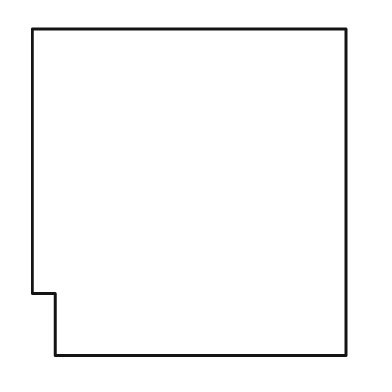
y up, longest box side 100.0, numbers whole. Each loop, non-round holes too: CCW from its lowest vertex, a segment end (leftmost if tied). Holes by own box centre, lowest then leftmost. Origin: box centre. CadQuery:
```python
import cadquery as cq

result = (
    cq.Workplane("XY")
    .moveTo(-41.0, -50.0)
    .lineTo(48.0, -50.0)
    .lineTo(48.0, 50.0)
    .lineTo(-48.0, 50.0)
    .lineTo(-48.0, -31.0)
    .lineTo(-41.0, -31.0)
    .close()
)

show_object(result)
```